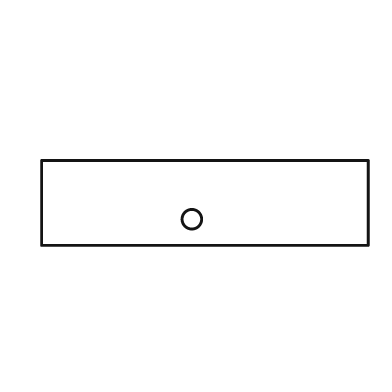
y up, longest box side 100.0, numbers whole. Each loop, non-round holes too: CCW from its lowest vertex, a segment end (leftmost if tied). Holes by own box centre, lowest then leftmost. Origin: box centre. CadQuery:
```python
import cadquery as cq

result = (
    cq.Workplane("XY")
    .moveTo(-50.0, -13.0)
    .lineTo(50.0, -13.0)
    .lineTo(50.0, 13.0)
    .lineTo(-50.0, 13.0)
    .close()
    .moveTo(-4.0, -5.0)
    .circle(3.0)
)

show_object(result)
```